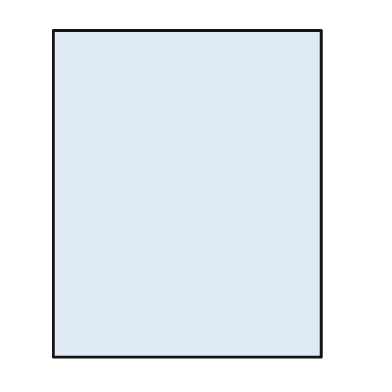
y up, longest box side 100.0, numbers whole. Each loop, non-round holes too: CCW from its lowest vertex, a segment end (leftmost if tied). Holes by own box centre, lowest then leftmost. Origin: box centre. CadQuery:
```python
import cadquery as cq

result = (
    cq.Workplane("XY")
    .moveTo(-41.0, -50.0)
    .lineTo(41.0, -50.0)
    .lineTo(41.0, 50.0)
    .lineTo(-41.0, 50.0)
    .close()
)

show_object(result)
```